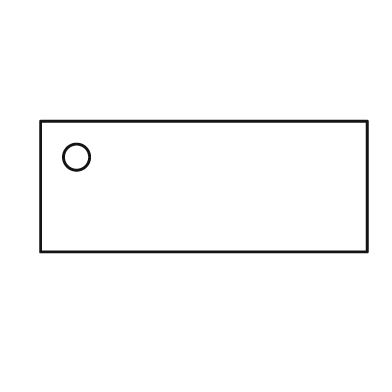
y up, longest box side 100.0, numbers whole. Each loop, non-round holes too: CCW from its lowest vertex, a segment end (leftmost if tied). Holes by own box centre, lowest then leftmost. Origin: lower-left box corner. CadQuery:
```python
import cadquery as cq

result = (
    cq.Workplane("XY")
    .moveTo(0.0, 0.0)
    .lineTo(100.0, 0.0)
    .lineTo(100.0, 40.0)
    .lineTo(0.0, 40.0)
    .close()
    .moveTo(11.0, 29.0)
    .circle(4.0)
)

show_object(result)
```